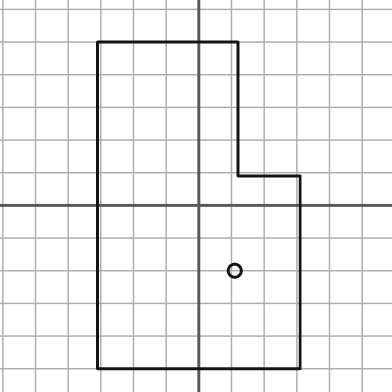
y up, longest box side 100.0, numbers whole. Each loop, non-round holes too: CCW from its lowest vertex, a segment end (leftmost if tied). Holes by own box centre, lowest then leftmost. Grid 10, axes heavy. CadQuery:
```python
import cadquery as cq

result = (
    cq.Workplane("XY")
    .moveTo(-31.0, -50.0)
    .lineTo(31.0, -50.0)
    .lineTo(31.0, 9.0)
    .lineTo(12.0, 9.0)
    .lineTo(12.0, 50.0)
    .lineTo(-31.0, 50.0)
    .close()
    .moveTo(11.0, -20.0)
    .circle(2.0)
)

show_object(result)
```